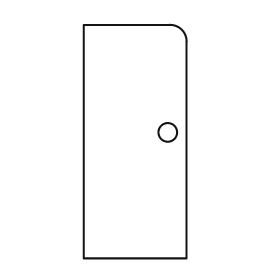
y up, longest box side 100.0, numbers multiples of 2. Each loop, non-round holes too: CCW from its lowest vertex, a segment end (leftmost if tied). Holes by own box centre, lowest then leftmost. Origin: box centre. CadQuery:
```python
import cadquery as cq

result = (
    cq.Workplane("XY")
    .moveTo(-22.0, -50.0)
    .lineTo(22.0, -50.0)
    .lineTo(22.0, 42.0)
    .threePointArc((20.0, 48.0), (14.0, 50.0))
    .lineTo(-22.0, 50.0)
    .close()
    .moveTo(14.0, 4.0)
    .circle(4.0)
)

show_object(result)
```